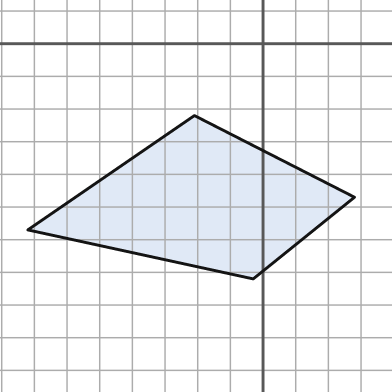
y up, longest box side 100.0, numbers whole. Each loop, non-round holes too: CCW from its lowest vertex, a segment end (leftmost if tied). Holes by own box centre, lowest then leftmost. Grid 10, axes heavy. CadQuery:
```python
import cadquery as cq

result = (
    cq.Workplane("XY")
    .moveTo(-3.0, -72.0)
    .lineTo(28.0, -47.0)
    .lineTo(-21.0, -22.0)
    .lineTo(-72.0, -57.0)
    .close()
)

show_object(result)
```